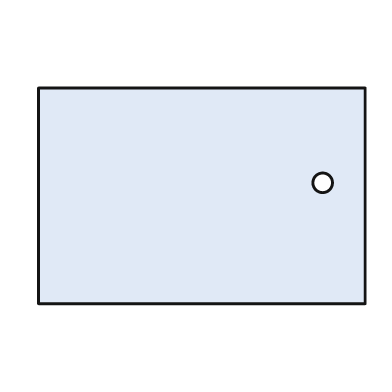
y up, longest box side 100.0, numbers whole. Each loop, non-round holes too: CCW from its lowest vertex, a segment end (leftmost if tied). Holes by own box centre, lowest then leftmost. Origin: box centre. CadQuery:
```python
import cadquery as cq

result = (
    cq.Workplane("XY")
    .moveTo(-50.0, -33.0)
    .lineTo(50.0, -33.0)
    .lineTo(50.0, 33.0)
    .lineTo(-50.0, 33.0)
    .close()
    .moveTo(37.0, 4.0)
    .circle(3.0)
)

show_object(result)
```